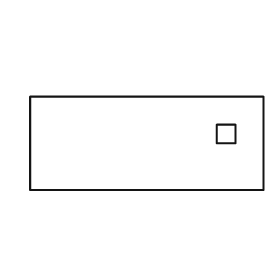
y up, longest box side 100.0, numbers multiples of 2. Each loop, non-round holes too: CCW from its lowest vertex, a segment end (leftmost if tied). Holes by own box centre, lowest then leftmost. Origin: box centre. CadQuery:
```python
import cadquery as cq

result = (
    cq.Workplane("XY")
    .moveTo(-50.0, -20.0)
    .lineTo(50.0, -20.0)
    .lineTo(50.0, 20.0)
    .lineTo(-50.0, 20.0)
    .close()
    .moveTo(30.0, 0.0)
    .lineTo(38.0, 0.0)
    .lineTo(38.0, 8.0)
    .lineTo(30.0, 8.0)
    .close()
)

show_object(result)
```